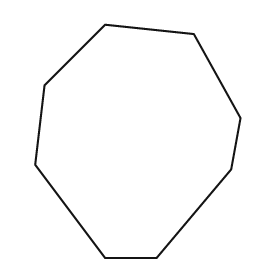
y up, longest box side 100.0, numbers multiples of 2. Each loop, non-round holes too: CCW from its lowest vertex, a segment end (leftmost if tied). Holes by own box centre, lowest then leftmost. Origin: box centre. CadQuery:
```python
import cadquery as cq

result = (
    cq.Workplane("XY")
    .moveTo(-14.0, -50.0)
    .lineTo(8.0, -50.0)
    .lineTo(40.0, -12.0)
    .lineTo(44.0, 10.0)
    .lineTo(24.0, 46.0)
    .lineTo(-14.0, 50.0)
    .lineTo(-40.0, 24.0)
    .lineTo(-44.0, -10.0)
    .close()
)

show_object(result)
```